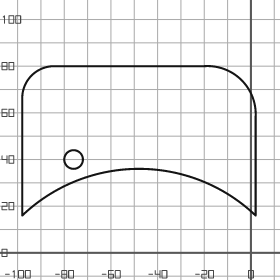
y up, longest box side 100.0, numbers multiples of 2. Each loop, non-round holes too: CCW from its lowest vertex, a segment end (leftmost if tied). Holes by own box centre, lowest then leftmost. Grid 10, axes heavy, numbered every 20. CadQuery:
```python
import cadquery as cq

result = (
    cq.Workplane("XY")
    .moveTo(-98.0, 16.0)
    .threePointArc((-48.0, 36.0), (2.0, 16.0))
    .lineTo(2.0, 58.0)
    .threePointArc((-4.0, 74.0), (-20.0, 80.0))
    .lineTo(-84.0, 80.0)
    .threePointArc((-94.0, 76.0), (-98.0, 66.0))
    .close()
    .moveTo(-76.0, 40.0)
    .circle(4.0)
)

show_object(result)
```